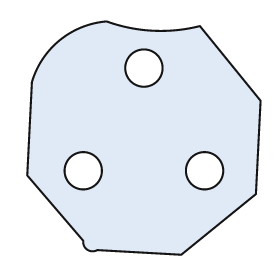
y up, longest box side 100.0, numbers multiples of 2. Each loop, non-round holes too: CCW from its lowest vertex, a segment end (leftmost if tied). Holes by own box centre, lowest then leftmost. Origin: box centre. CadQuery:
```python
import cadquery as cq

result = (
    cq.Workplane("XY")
    .moveTo(16.0, -50.0)
    .lineTo(48.0, -24.0)
    .lineTo(50.0, 16.0)
    .lineTo(24.0, 48.0)
    .threePointArc((4.0, 46.0), (-16.0, 50.0))
    .threePointArc((-36.0, 42.0), (-48.0, 24.0))
    .lineTo(-50.0, -16.0)
    .lineTo(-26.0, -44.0)
    .threePointArc((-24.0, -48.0), (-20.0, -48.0))
    .close()
    .moveTo(-26.0, -14.0)
    .circle(8.0)
    .moveTo(26.0, -14.0)
    .circle(8.0)
    .moveTo(0.0, 30.0)
    .circle(8.0)
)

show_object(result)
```